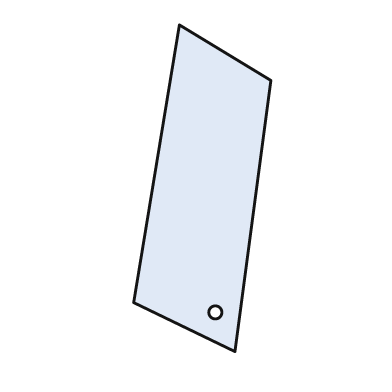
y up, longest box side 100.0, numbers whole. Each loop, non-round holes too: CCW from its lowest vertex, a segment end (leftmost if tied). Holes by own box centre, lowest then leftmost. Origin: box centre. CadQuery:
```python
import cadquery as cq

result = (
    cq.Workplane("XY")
    .moveTo(10.0, -50.0)
    .lineTo(21.0, 33.0)
    .lineTo(-7.0, 50.0)
    .lineTo(-21.0, -35.0)
    .close()
    .moveTo(4.0, -38.0)
    .circle(2.0)
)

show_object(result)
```